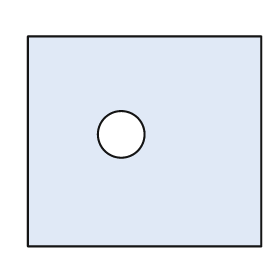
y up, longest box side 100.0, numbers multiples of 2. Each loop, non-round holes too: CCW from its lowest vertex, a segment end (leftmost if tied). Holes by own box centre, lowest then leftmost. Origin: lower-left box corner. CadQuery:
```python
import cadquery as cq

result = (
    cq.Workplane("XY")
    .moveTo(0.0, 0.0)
    .lineTo(100.0, 0.0)
    .lineTo(100.0, 90.0)
    .lineTo(0.0, 90.0)
    .close()
    .moveTo(40.0, 48.0)
    .circle(10.0)
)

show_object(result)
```